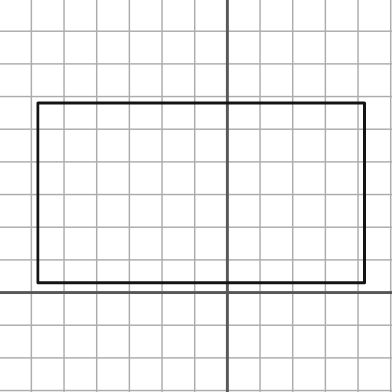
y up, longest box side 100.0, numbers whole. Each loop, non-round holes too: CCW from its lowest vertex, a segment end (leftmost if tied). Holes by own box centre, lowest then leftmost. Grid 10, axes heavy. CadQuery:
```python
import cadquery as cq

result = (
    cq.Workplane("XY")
    .moveTo(-58.0, 3.0)
    .lineTo(42.0, 3.0)
    .lineTo(42.0, 58.0)
    .lineTo(-58.0, 58.0)
    .close()
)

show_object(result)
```